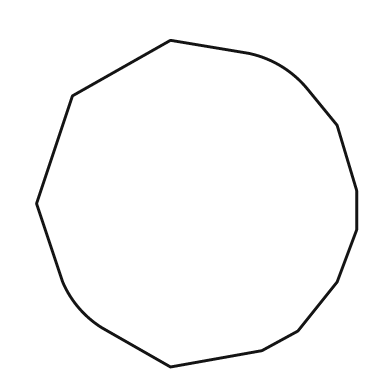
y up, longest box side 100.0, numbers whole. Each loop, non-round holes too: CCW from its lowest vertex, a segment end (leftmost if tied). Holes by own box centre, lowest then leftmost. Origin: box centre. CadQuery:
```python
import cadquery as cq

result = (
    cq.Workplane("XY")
    .moveTo(-8.0, -50.0)
    .lineTo(20.0, -45.0)
    .lineTo(31.0, -39.0)
    .lineTo(43.0, -24.0)
    .lineTo(49.0, -8.0)
    .lineTo(49.0, 4.0)
    .lineTo(43.0, 24.0)
    .lineTo(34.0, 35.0)
    .threePointArc((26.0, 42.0), (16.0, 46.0))
    .lineTo(-8.0, 50.0)
    .lineTo(-38.0, 33.0)
    .lineTo(-49.0, 0.0)
    .lineTo(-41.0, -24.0)
    .threePointArc((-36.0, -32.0), (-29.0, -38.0))
    .close()
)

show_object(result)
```